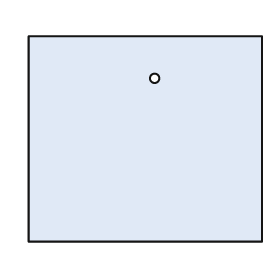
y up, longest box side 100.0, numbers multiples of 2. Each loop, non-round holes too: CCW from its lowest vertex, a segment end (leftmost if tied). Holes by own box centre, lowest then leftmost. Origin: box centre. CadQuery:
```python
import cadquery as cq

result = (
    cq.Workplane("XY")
    .moveTo(-50.0, -44.0)
    .lineTo(50.0, -44.0)
    .lineTo(50.0, 44.0)
    .lineTo(-50.0, 44.0)
    .close()
    .moveTo(4.0, 26.0)
    .circle(2.0)
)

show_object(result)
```